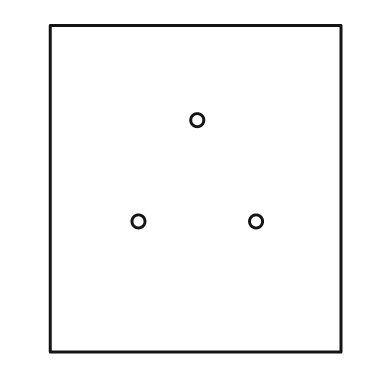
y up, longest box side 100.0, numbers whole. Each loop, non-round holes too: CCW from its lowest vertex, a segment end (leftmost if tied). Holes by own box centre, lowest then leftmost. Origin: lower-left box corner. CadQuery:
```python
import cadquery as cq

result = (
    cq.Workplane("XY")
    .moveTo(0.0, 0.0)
    .lineTo(89.0, 0.0)
    .lineTo(89.0, 100.0)
    .lineTo(0.0, 100.0)
    .close()
    .moveTo(27.0, 40.0)
    .circle(2.0)
    .moveTo(63.0, 40.0)
    .circle(2.0)
    .moveTo(45.0, 71.0)
    .circle(2.0)
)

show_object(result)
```